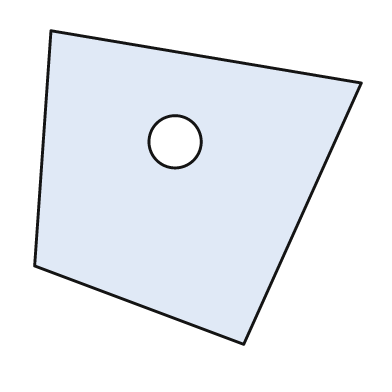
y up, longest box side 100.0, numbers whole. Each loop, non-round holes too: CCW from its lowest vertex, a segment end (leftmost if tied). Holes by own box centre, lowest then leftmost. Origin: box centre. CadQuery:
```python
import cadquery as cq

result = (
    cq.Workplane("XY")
    .moveTo(14.0, -48.0)
    .lineTo(50.0, 32.0)
    .lineTo(-45.0, 48.0)
    .lineTo(-50.0, -24.0)
    .close()
    .moveTo(-7.0, 14.0)
    .circle(8.0)
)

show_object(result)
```